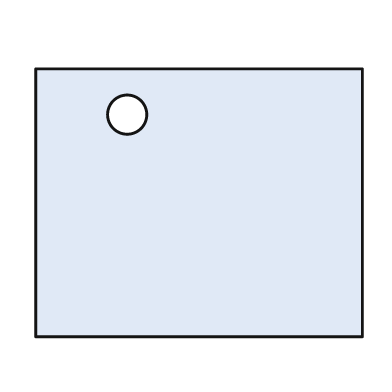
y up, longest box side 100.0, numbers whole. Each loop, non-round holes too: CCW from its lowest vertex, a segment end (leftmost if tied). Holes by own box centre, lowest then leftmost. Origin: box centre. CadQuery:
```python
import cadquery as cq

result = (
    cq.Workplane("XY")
    .moveTo(-50.0, -41.0)
    .lineTo(50.0, -41.0)
    .lineTo(50.0, 41.0)
    .lineTo(-50.0, 41.0)
    .close()
    .moveTo(-22.0, 27.0)
    .circle(6.0)
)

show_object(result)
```